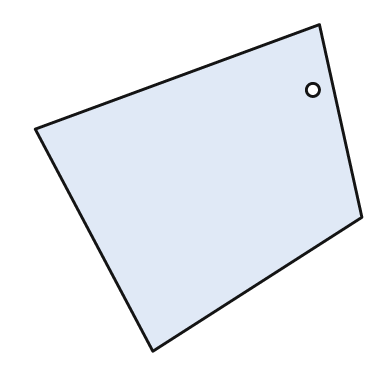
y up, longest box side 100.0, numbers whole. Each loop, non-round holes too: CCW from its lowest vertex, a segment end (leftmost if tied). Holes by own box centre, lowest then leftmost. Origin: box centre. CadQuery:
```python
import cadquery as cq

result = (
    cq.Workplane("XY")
    .moveTo(-14.0, -50.0)
    .lineTo(50.0, -9.0)
    .lineTo(37.0, 50.0)
    .lineTo(-50.0, 18.0)
    .close()
    .moveTo(35.0, 30.0)
    .circle(2.0)
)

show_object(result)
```